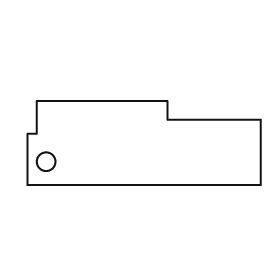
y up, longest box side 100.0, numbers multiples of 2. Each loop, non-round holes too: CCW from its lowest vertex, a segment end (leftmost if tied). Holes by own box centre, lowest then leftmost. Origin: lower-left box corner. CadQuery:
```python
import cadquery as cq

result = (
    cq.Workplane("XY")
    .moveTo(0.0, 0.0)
    .lineTo(100.0, 0.0)
    .lineTo(100.0, 28.0)
    .lineTo(60.0, 28.0)
    .lineTo(60.0, 36.0)
    .lineTo(4.0, 36.0)
    .lineTo(4.0, 22.0)
    .lineTo(0.0, 22.0)
    .close()
    .moveTo(8.0, 10.0)
    .circle(4.0)
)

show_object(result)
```